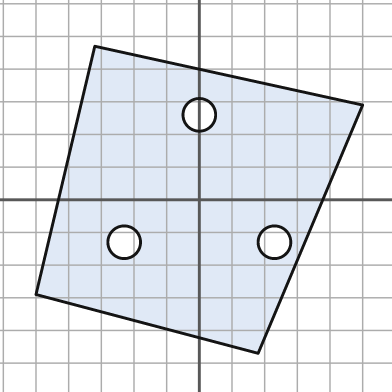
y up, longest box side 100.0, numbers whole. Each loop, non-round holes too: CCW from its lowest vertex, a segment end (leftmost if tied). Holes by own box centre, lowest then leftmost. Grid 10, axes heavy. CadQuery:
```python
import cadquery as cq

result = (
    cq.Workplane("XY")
    .moveTo(18.0, -47.0)
    .lineTo(50.0, 29.0)
    .lineTo(-32.0, 47.0)
    .lineTo(-50.0, -29.0)
    .close()
    .moveTo(-23.0, -13.0)
    .circle(5.0)
    .moveTo(23.0, -13.0)
    .circle(5.0)
    .moveTo(0.0, 26.0)
    .circle(5.0)
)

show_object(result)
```